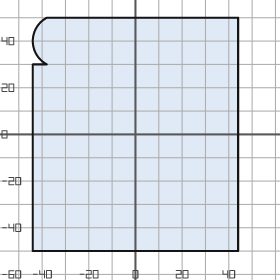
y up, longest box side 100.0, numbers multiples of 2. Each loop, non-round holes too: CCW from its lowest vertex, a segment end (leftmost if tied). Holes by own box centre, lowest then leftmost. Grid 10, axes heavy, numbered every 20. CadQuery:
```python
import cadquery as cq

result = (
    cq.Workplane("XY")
    .moveTo(-44.0, -50.0)
    .lineTo(44.0, -50.0)
    .lineTo(44.0, 50.0)
    .lineTo(-38.0, 50.0)
    .threePointArc((-44.0, 40.0), (-38.0, 30.0))
    .lineTo(-44.0, 30.0)
    .close()
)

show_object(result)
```